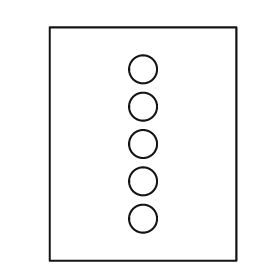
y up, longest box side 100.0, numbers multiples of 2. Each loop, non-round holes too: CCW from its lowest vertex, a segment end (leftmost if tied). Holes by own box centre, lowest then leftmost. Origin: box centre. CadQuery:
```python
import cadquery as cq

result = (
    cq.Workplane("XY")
    .moveTo(-40.0, -50.0)
    .lineTo(40.0, -50.0)
    .lineTo(40.0, 50.0)
    .lineTo(-40.0, 50.0)
    .close()
    .moveTo(0.0, -32.0)
    .circle(6.0)
    .moveTo(0.0, -16.0)
    .circle(6.0)
    .moveTo(0.0, 0.0)
    .circle(6.0)
    .moveTo(0.0, 16.0)
    .circle(6.0)
    .moveTo(0.0, 32.0)
    .circle(6.0)
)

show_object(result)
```